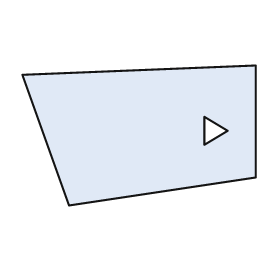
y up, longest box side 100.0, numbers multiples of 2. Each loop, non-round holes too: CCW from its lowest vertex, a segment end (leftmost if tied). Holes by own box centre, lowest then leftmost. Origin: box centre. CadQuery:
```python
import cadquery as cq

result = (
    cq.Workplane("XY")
    .moveTo(-30.0, -30.0)
    .lineTo(50.0, -18.0)
    .lineTo(50.0, 30.0)
    .lineTo(-50.0, 26.0)
    .close()
    .moveTo(28.0, -4.0)
    .lineTo(38.0, 2.0)
    .lineTo(28.0, 8.0)
    .close()
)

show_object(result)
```